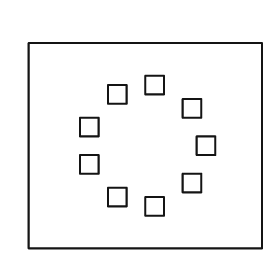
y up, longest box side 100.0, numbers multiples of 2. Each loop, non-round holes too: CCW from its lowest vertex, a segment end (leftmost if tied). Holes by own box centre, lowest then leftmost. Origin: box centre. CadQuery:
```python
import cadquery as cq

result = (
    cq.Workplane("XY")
    .moveTo(-50.0, -44.0)
    .lineTo(50.0, -44.0)
    .lineTo(50.0, 44.0)
    .lineTo(-50.0, 44.0)
    .close()
    .moveTo(0.0, -30.0)
    .lineTo(8.0, -30.0)
    .lineTo(8.0, -22.0)
    .lineTo(0.0, -22.0)
    .close()
    .moveTo(-16.0, -26.0)
    .lineTo(-8.0, -26.0)
    .lineTo(-8.0, -18.0)
    .lineTo(-16.0, -18.0)
    .close()
    .moveTo(16.0, -20.0)
    .lineTo(24.0, -20.0)
    .lineTo(24.0, -12.0)
    .lineTo(16.0, -12.0)
    .close()
    .moveTo(-28.0, -12.0)
    .lineTo(-20.0, -12.0)
    .lineTo(-20.0, -4.0)
    .lineTo(-28.0, -4.0)
    .close()
    .moveTo(22.0, -4.0)
    .lineTo(30.0, -4.0)
    .lineTo(30.0, 4.0)
    .lineTo(22.0, 4.0)
    .close()
    .moveTo(-28.0, 4.0)
    .lineTo(-20.0, 4.0)
    .lineTo(-20.0, 12.0)
    .lineTo(-28.0, 12.0)
    .close()
    .moveTo(16.0, 12.0)
    .lineTo(24.0, 12.0)
    .lineTo(24.0, 20.0)
    .lineTo(16.0, 20.0)
    .close()
    .moveTo(-16.0, 18.0)
    .lineTo(-8.0, 18.0)
    .lineTo(-8.0, 26.0)
    .lineTo(-16.0, 26.0)
    .close()
    .moveTo(0.0, 22.0)
    .lineTo(8.0, 22.0)
    .lineTo(8.0, 30.0)
    .lineTo(0.0, 30.0)
    .close()
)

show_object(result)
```